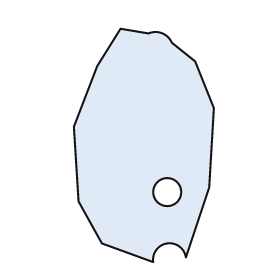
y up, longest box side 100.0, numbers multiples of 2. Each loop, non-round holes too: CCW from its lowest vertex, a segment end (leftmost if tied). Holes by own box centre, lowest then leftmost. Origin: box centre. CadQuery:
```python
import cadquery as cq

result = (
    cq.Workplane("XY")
    .moveTo(4.0, -50.0)
    .threePointArc((10.0, -42.0), (18.0, -48.0))
    .lineTo(28.0, -18.0)
    .lineTo(30.0, 16.0)
    .lineTo(22.0, 36.0)
    .lineTo(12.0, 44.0)
    .threePointArc((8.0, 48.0), (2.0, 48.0))
    .lineTo(-10.0, 50.0)
    .lineTo(-20.0, 34.0)
    .lineTo(-30.0, 8.0)
    .lineTo(-28.0, -24.0)
    .lineTo(-18.0, -42.0)
    .close()
    .moveTo(10.0, -20.0)
    .circle(6.0)
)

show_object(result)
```